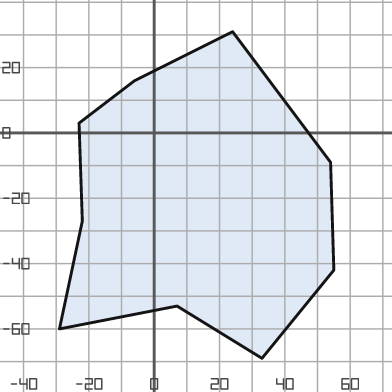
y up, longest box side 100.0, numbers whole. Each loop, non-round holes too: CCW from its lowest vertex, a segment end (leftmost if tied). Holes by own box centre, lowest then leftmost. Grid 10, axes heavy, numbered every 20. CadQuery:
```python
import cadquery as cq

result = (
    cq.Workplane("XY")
    .moveTo(33.0, -69.0)
    .lineTo(55.0, -42.0)
    .lineTo(54.0, -9.0)
    .lineTo(24.0, 31.0)
    .lineTo(-6.0, 16.0)
    .lineTo(-23.0, 3.0)
    .lineTo(-22.0, -27.0)
    .lineTo(-29.0, -60.0)
    .lineTo(7.0, -53.0)
    .close()
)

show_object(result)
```